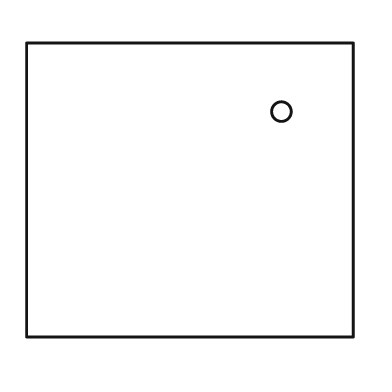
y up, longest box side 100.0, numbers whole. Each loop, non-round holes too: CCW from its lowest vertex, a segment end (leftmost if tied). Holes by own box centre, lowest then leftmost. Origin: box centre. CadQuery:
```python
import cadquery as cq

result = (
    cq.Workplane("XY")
    .moveTo(-50.0, -45.0)
    .lineTo(50.0, -45.0)
    .lineTo(50.0, 45.0)
    .lineTo(-50.0, 45.0)
    .close()
    .moveTo(28.0, 24.0)
    .circle(3.0)
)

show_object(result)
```